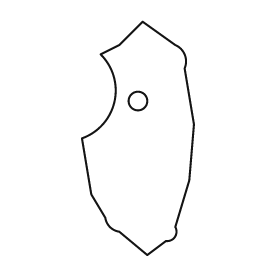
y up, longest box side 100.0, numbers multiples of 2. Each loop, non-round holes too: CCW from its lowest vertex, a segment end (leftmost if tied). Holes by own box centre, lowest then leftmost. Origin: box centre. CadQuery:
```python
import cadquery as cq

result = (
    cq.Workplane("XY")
    .moveTo(4.0, -50.0)
    .lineTo(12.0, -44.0)
    .threePointArc((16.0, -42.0), (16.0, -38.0))
    .lineTo(22.0, -18.0)
    .lineTo(24.0, 6.0)
    .lineTo(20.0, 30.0)
    .threePointArc((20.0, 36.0), (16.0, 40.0))
    .lineTo(2.0, 50.0)
    .lineTo(-8.0, 40.0)
    .lineTo(-16.0, 36.0)
    .threePointArc((-10.0, 16.0), (-24.0, 0.0))
    .lineTo(-20.0, -24.0)
    .lineTo(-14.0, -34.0)
    .threePointArc((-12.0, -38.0), (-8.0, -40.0))
    .close()
    .moveTo(0.0, 16.0)
    .circle(4.0)
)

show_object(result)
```